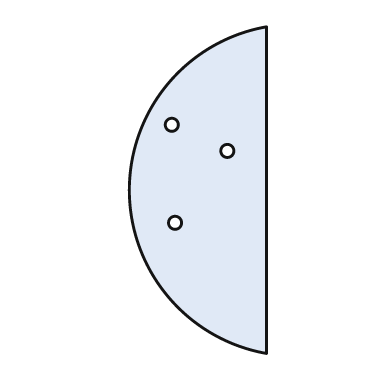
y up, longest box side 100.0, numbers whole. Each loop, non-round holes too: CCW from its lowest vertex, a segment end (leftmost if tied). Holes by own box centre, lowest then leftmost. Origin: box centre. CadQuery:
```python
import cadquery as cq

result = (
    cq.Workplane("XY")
    .moveTo(21.0, -50.0)
    .lineTo(21.0, 50.0)
    .threePointArc((-21.0, 0.0), (21.0, -50.0))
    .close()
    .moveTo(-7.0, -10.0)
    .circle(2.0)
    .moveTo(9.0, 12.0)
    .circle(2.0)
    .moveTo(-8.0, 20.0)
    .circle(2.0)
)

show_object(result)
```